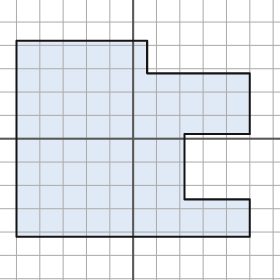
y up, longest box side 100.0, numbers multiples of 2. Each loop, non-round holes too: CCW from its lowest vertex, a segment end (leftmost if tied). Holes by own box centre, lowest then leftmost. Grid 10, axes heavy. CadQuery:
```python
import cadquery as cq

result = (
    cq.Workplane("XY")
    .moveTo(-50.0, -42.0)
    .lineTo(50.0, -42.0)
    .lineTo(50.0, -26.0)
    .lineTo(22.0, -26.0)
    .lineTo(22.0, 2.0)
    .lineTo(50.0, 2.0)
    .lineTo(50.0, 28.0)
    .lineTo(6.0, 28.0)
    .lineTo(6.0, 42.0)
    .lineTo(-50.0, 42.0)
    .close()
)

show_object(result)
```